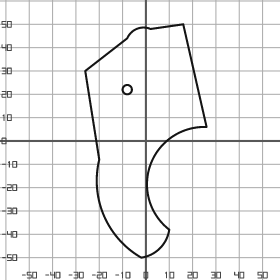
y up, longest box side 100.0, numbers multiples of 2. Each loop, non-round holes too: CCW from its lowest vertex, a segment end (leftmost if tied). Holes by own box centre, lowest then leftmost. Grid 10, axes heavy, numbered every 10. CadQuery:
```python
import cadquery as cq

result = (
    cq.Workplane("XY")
    .moveTo(-2.0, -50.0)
    .threePointArc((6.0, -46.0), (10.0, -38.0))
    .threePointArc((2.0, -10.0), (26.0, 6.0))
    .lineTo(16.0, 50.0)
    .lineTo(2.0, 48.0)
    .threePointArc((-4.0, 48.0), (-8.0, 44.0))
    .lineTo(-26.0, 30.0)
    .lineTo(-20.0, -8.0)
    .threePointArc((-18.0, -32.0), (-2.0, -50.0))
    .close()
    .moveTo(-8.0, 22.0)
    .circle(2.0)
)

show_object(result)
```